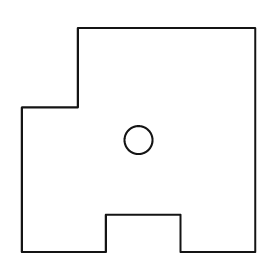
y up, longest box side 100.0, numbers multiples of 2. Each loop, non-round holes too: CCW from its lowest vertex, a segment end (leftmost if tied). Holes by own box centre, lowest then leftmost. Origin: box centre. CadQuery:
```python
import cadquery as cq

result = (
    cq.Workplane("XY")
    .moveTo(-50.0, -48.0)
    .lineTo(-14.0, -48.0)
    .lineTo(-14.0, -32.0)
    .lineTo(18.0, -32.0)
    .lineTo(18.0, -48.0)
    .lineTo(50.0, -48.0)
    .lineTo(50.0, 48.0)
    .lineTo(-26.0, 48.0)
    .lineTo(-26.0, 14.0)
    .lineTo(-50.0, 14.0)
    .close()
    .moveTo(0.0, 0.0)
    .circle(6.0)
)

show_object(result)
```